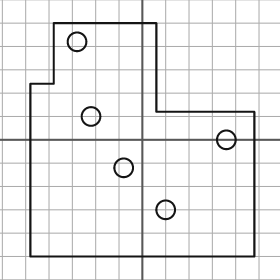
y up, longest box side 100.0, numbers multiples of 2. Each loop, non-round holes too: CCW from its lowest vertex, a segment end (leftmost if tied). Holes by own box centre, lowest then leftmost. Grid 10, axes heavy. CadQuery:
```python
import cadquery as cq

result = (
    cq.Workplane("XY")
    .moveTo(-48.0, -50.0)
    .lineTo(48.0, -50.0)
    .lineTo(48.0, 12.0)
    .lineTo(6.0, 12.0)
    .lineTo(6.0, 50.0)
    .lineTo(-38.0, 50.0)
    .lineTo(-38.0, 24.0)
    .lineTo(-48.0, 24.0)
    .close()
    .moveTo(10.0, -30.0)
    .circle(4.0)
    .moveTo(-8.0, -12.0)
    .circle(4.0)
    .moveTo(36.0, 0.0)
    .circle(4.0)
    .moveTo(-22.0, 10.0)
    .circle(4.0)
    .moveTo(-28.0, 42.0)
    .circle(4.0)
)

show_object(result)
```